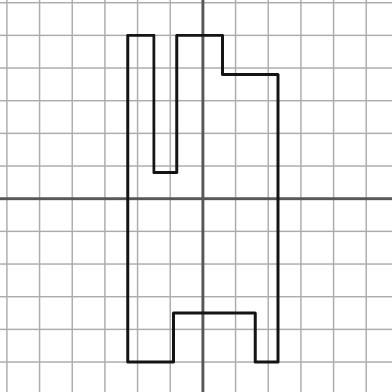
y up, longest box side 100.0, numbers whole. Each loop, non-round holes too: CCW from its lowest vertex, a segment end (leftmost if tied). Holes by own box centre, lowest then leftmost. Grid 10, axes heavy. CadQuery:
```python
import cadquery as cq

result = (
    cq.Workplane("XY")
    .moveTo(-23.0, -50.0)
    .lineTo(-9.0, -50.0)
    .lineTo(-9.0, -35.0)
    .lineTo(16.0, -35.0)
    .lineTo(16.0, -50.0)
    .lineTo(23.0, -50.0)
    .lineTo(23.0, 38.0)
    .lineTo(6.0, 38.0)
    .lineTo(6.0, 50.0)
    .lineTo(-8.0, 50.0)
    .lineTo(-8.0, 8.0)
    .lineTo(-15.0, 8.0)
    .lineTo(-15.0, 50.0)
    .lineTo(-23.0, 50.0)
    .close()
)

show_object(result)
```